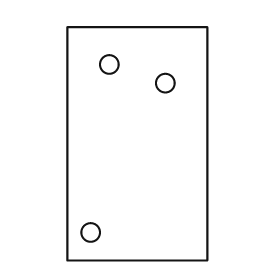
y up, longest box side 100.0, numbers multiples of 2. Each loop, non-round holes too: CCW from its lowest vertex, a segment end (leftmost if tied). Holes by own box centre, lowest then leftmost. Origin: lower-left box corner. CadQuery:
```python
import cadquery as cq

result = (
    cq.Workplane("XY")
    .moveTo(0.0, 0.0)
    .lineTo(60.0, 0.0)
    .lineTo(60.0, 100.0)
    .lineTo(0.0, 100.0)
    .close()
    .moveTo(10.0, 12.0)
    .circle(4.0)
    .moveTo(42.0, 76.0)
    .circle(4.0)
    .moveTo(18.0, 84.0)
    .circle(4.0)
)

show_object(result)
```